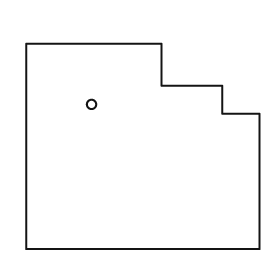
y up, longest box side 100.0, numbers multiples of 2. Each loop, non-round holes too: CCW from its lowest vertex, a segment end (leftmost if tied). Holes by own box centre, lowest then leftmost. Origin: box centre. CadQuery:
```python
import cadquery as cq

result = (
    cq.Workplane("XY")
    .moveTo(-50.0, -44.0)
    .lineTo(50.0, -44.0)
    .lineTo(50.0, 14.0)
    .lineTo(34.0, 14.0)
    .lineTo(34.0, 26.0)
    .lineTo(8.0, 26.0)
    .lineTo(8.0, 44.0)
    .lineTo(-50.0, 44.0)
    .close()
    .moveTo(-22.0, 18.0)
    .circle(2.0)
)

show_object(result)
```